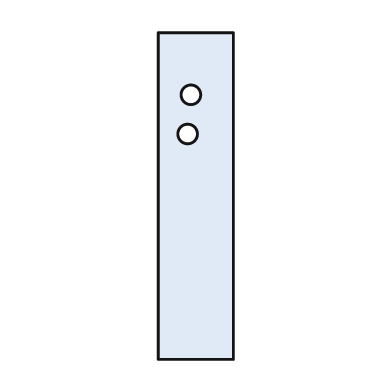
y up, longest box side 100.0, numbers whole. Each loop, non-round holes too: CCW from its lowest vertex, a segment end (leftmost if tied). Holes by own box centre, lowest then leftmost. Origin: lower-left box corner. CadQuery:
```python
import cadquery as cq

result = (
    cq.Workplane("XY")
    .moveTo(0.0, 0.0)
    .lineTo(23.0, 0.0)
    .lineTo(23.0, 100.0)
    .lineTo(0.0, 100.0)
    .close()
    .moveTo(9.0, 69.0)
    .circle(3.0)
    .moveTo(10.0, 81.0)
    .circle(3.0)
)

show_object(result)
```